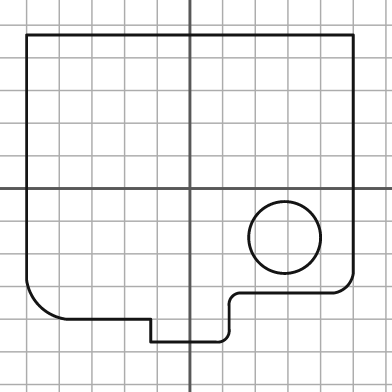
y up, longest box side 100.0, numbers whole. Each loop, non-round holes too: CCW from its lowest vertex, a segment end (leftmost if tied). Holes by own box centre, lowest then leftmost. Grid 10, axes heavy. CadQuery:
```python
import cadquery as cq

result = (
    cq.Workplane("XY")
    .moveTo(-12.0, -47.0)
    .lineTo(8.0, -47.0)
    .threePointArc((11.0, -46.0), (12.0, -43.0))
    .lineTo(12.0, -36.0)
    .threePointArc((13.0, -33.0), (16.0, -32.0))
    .lineTo(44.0, -32.0)
    .threePointArc((48.0, -30.0), (50.0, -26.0))
    .lineTo(50.0, 47.0)
    .lineTo(-50.0, 47.0)
    .lineTo(-50.0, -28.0)
    .threePointArc((-46.0, -36.0), (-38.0, -40.0))
    .lineTo(-12.0, -40.0)
    .close()
    .moveTo(29.0, -15.0)
    .circle(11.0)
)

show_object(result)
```